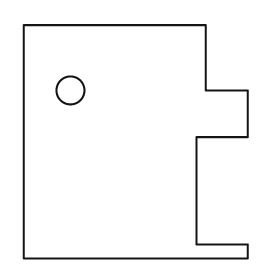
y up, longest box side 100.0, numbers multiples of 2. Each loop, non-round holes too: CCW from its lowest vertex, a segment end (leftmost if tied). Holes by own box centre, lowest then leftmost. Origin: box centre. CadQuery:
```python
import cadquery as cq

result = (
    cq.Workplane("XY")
    .moveTo(-48.0, -50.0)
    .lineTo(48.0, -50.0)
    .lineTo(48.0, -44.0)
    .lineTo(26.0, -44.0)
    .lineTo(26.0, 2.0)
    .lineTo(48.0, 2.0)
    .lineTo(48.0, 22.0)
    .lineTo(30.0, 22.0)
    .lineTo(30.0, 50.0)
    .lineTo(-48.0, 50.0)
    .close()
    .moveTo(-28.0, 22.0)
    .circle(6.0)
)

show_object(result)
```